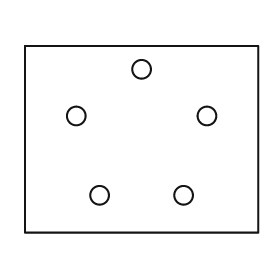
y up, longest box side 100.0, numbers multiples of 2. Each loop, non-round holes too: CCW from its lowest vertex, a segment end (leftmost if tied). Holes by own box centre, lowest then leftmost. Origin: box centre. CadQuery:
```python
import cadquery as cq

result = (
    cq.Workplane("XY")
    .moveTo(-50.0, -40.0)
    .lineTo(50.0, -40.0)
    .lineTo(50.0, 40.0)
    .lineTo(-50.0, 40.0)
    .close()
    .moveTo(-18.0, -24.0)
    .circle(4.0)
    .moveTo(18.0, -24.0)
    .circle(4.0)
    .moveTo(-28.0, 10.0)
    .circle(4.0)
    .moveTo(28.0, 10.0)
    .circle(4.0)
    .moveTo(0.0, 30.0)
    .circle(4.0)
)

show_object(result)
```